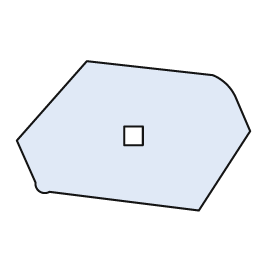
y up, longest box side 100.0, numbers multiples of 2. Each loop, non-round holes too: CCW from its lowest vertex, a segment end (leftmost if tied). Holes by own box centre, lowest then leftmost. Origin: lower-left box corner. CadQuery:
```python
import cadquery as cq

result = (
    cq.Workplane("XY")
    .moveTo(78.0, 0.0)
    .lineTo(100.0, 34.0)
    .lineTo(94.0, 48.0)
    .threePointArc((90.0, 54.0), (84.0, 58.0))
    .lineTo(30.0, 64.0)
    .lineTo(0.0, 30.0)
    .lineTo(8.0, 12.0)
    .threePointArc((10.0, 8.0), (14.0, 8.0))
    .close()
    .moveTo(46.0, 28.0)
    .lineTo(54.0, 28.0)
    .lineTo(54.0, 36.0)
    .lineTo(46.0, 36.0)
    .close()
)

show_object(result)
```